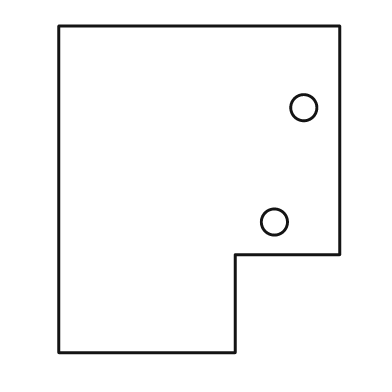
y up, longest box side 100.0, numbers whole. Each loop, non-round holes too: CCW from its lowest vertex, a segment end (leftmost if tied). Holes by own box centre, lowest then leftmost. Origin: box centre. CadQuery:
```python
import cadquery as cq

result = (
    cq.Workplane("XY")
    .moveTo(-43.0, -50.0)
    .lineTo(11.0, -50.0)
    .lineTo(11.0, -20.0)
    .lineTo(43.0, -20.0)
    .lineTo(43.0, 50.0)
    .lineTo(-43.0, 50.0)
    .close()
    .moveTo(23.0, -10.0)
    .circle(4.0)
    .moveTo(32.0, 25.0)
    .circle(4.0)
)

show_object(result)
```